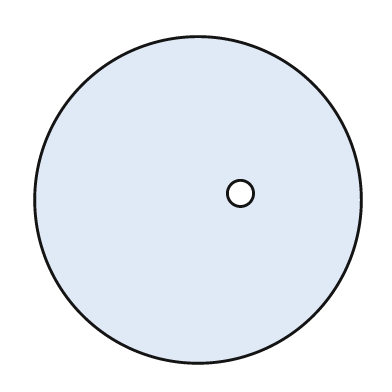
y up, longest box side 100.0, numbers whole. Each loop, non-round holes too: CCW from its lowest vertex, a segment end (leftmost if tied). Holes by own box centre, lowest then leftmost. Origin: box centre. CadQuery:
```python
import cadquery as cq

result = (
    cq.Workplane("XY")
    .moveTo(0.0, 0.0)
    .circle(50.0)
    .moveTo(13.0, 2.0)
    .circle(4.0)
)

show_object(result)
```